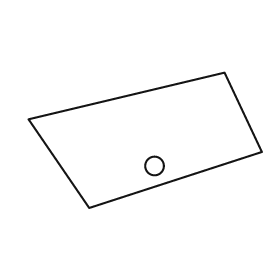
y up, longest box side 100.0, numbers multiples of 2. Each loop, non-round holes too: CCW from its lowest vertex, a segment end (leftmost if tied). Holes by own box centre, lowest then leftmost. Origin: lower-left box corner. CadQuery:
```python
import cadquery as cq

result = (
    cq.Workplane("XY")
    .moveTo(26.0, 0.0)
    .lineTo(100.0, 24.0)
    .lineTo(84.0, 58.0)
    .lineTo(0.0, 38.0)
    .close()
    .moveTo(54.0, 18.0)
    .circle(4.0)
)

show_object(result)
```